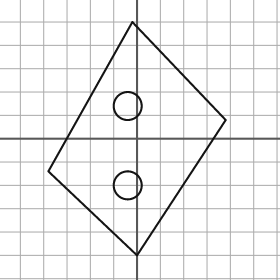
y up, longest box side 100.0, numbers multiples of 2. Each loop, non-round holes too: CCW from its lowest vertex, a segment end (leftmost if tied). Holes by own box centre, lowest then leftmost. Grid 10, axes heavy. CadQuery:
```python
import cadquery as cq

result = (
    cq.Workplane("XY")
    .moveTo(0.0, -50.0)
    .lineTo(38.0, 8.0)
    .lineTo(-2.0, 50.0)
    .lineTo(-38.0, -14.0)
    .close()
    .moveTo(-4.0, -20.0)
    .circle(6.0)
    .moveTo(-4.0, 14.0)
    .circle(6.0)
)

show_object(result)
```